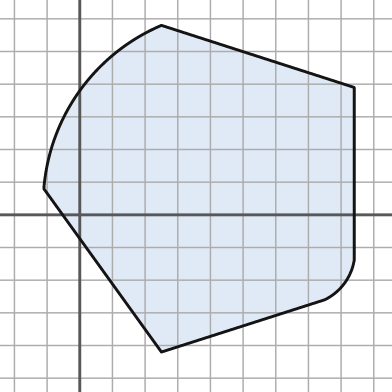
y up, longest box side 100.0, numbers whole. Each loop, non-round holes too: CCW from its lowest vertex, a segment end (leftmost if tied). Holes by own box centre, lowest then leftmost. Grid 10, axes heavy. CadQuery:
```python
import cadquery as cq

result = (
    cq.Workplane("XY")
    .moveTo(25.0, -42.0)
    .lineTo(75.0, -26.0)
    .threePointArc((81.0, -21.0), (84.0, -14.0))
    .lineTo(84.0, 39.0)
    .lineTo(25.0, 58.0)
    .threePointArc((0.0, 38.0), (-11.0, 8.0))
    .close()
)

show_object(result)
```